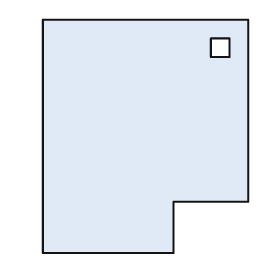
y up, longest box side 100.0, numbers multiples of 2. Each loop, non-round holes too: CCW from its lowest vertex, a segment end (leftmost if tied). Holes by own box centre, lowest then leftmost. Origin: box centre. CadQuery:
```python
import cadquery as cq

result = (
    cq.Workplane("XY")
    .moveTo(-44.0, -50.0)
    .lineTo(12.0, -50.0)
    .lineTo(12.0, -28.0)
    .lineTo(44.0, -28.0)
    .lineTo(44.0, 50.0)
    .lineTo(-44.0, 50.0)
    .close()
    .moveTo(28.0, 34.0)
    .lineTo(36.0, 34.0)
    .lineTo(36.0, 42.0)
    .lineTo(28.0, 42.0)
    .close()
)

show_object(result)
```